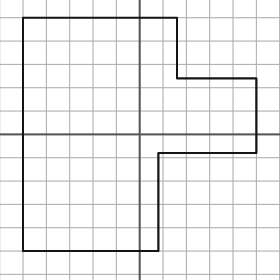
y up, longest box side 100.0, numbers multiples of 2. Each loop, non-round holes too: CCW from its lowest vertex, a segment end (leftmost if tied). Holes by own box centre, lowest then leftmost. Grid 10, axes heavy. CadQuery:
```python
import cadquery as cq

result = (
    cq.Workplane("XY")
    .moveTo(-50.0, -50.0)
    .lineTo(8.0, -50.0)
    .lineTo(8.0, -8.0)
    .lineTo(50.0, -8.0)
    .lineTo(50.0, 24.0)
    .lineTo(16.0, 24.0)
    .lineTo(16.0, 50.0)
    .lineTo(-50.0, 50.0)
    .close()
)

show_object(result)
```